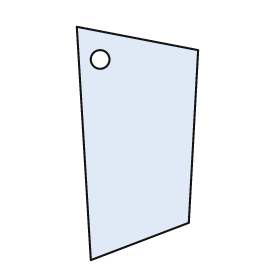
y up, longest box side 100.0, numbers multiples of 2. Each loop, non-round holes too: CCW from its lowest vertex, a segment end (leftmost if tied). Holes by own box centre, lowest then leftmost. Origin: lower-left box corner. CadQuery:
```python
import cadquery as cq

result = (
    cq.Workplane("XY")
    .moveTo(6.0, 0.0)
    .lineTo(48.0, 16.0)
    .lineTo(52.0, 90.0)
    .lineTo(0.0, 100.0)
    .close()
    .moveTo(10.0, 86.0)
    .circle(4.0)
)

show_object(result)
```